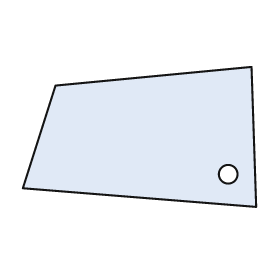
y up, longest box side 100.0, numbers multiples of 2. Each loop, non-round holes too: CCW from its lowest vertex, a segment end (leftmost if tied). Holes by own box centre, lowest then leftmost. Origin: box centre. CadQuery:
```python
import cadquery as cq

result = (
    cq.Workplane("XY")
    .moveTo(50.0, -30.0)
    .lineTo(48.0, 30.0)
    .lineTo(-36.0, 22.0)
    .lineTo(-50.0, -22.0)
    .close()
    .moveTo(38.0, -16.0)
    .circle(4.0)
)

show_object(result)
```